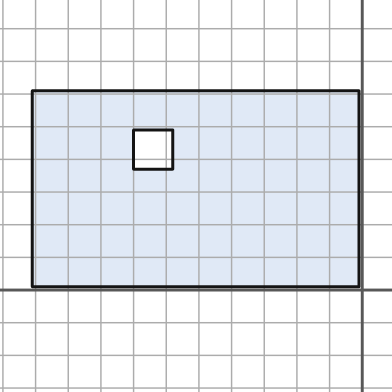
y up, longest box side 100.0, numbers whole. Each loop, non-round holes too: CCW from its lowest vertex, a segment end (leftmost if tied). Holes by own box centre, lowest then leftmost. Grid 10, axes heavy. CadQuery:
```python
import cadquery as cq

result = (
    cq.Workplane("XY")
    .moveTo(-101.0, 1.0)
    .lineTo(-1.0, 1.0)
    .lineTo(-1.0, 61.0)
    .lineTo(-101.0, 61.0)
    .close()
    .moveTo(-70.0, 37.0)
    .lineTo(-58.0, 37.0)
    .lineTo(-58.0, 49.0)
    .lineTo(-70.0, 49.0)
    .close()
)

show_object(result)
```